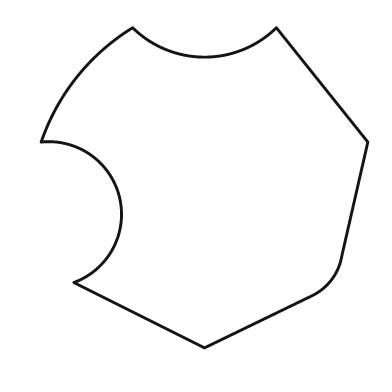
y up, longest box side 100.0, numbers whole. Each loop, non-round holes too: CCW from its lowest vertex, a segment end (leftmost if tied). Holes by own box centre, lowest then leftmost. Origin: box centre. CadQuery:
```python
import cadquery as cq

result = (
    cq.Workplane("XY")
    .moveTo(0.0, -49.0)
    .lineTo(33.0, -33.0)
    .threePointArc((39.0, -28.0), (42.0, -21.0))
    .lineTo(50.0, 14.0)
    .lineTo(22.0, 49.0)
    .threePointArc((0.0, 40.0), (-22.0, 49.0))
    .threePointArc((-39.0, 34.0), (-50.0, 14.0))
    .threePointArc((-26.0, -3.0), (-40.0, -29.0))
    .close()
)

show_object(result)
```